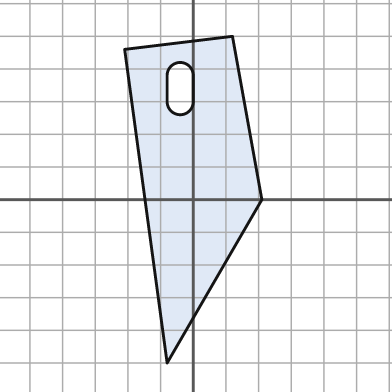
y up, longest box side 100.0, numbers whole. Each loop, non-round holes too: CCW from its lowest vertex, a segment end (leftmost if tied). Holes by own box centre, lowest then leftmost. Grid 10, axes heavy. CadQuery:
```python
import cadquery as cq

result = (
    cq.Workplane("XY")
    .moveTo(-8.0, -50.0)
    .lineTo(21.0, 0.0)
    .lineTo(12.0, 50.0)
    .lineTo(-21.0, 46.0)
    .close()
    .moveTo(-8.0, 30.0)
    .threePointArc((-4.0, 26.0), (0.0, 30.0))
    .lineTo(0.0, 38.0)
    .threePointArc((-4.0, 42.0), (-8.0, 38.0))
    .close()
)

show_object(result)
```